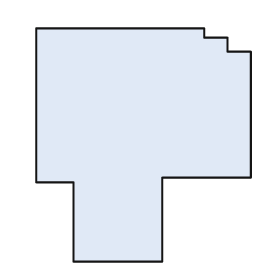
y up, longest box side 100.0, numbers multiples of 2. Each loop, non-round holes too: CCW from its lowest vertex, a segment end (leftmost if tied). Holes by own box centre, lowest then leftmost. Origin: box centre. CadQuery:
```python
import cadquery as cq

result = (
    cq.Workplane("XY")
    .moveTo(-30.0, -50.0)
    .lineTo(8.0, -50.0)
    .lineTo(8.0, -14.0)
    .lineTo(46.0, -14.0)
    .lineTo(46.0, 40.0)
    .lineTo(36.0, 40.0)
    .lineTo(36.0, 46.0)
    .lineTo(26.0, 46.0)
    .lineTo(26.0, 50.0)
    .lineTo(-46.0, 50.0)
    .lineTo(-46.0, -16.0)
    .lineTo(-30.0, -16.0)
    .close()
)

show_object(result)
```